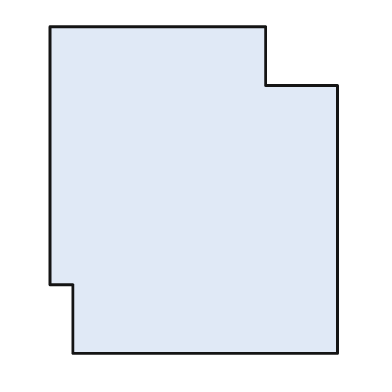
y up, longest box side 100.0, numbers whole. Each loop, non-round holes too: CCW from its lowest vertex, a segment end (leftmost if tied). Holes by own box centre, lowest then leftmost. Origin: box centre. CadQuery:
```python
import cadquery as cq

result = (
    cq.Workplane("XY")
    .moveTo(-37.0, -50.0)
    .lineTo(44.0, -50.0)
    .lineTo(44.0, 32.0)
    .lineTo(22.0, 32.0)
    .lineTo(22.0, 50.0)
    .lineTo(-44.0, 50.0)
    .lineTo(-44.0, -29.0)
    .lineTo(-37.0, -29.0)
    .close()
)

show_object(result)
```